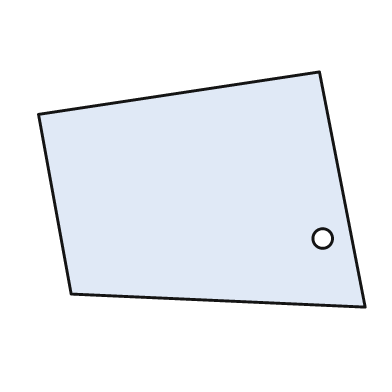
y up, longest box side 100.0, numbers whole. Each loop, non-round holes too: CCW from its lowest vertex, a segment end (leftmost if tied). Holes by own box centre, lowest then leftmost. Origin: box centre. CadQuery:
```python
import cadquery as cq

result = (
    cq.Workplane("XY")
    .moveTo(50.0, -36.0)
    .lineTo(36.0, 36.0)
    .lineTo(-50.0, 23.0)
    .lineTo(-40.0, -32.0)
    .close()
    .moveTo(37.0, -15.0)
    .circle(3.0)
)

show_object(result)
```